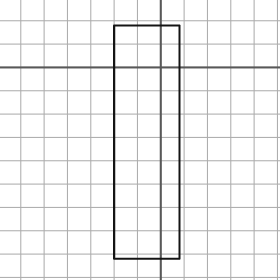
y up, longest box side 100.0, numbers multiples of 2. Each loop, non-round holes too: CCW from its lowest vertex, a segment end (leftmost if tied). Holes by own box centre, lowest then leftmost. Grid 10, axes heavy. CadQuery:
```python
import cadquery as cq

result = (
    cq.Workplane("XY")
    .moveTo(-20.0, -82.0)
    .lineTo(8.0, -82.0)
    .lineTo(8.0, 18.0)
    .lineTo(-20.0, 18.0)
    .close()
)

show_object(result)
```